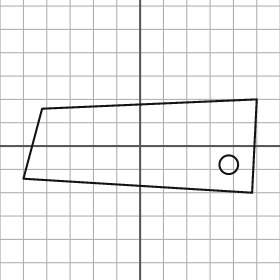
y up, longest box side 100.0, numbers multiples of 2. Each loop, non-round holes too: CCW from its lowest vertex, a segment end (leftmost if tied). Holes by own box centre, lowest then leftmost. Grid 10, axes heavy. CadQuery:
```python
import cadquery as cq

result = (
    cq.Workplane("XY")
    .moveTo(48.0, -20.0)
    .lineTo(50.0, 20.0)
    .lineTo(-42.0, 16.0)
    .lineTo(-50.0, -14.0)
    .close()
    .moveTo(38.0, -8.0)
    .circle(4.0)
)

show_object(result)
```